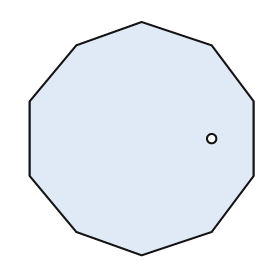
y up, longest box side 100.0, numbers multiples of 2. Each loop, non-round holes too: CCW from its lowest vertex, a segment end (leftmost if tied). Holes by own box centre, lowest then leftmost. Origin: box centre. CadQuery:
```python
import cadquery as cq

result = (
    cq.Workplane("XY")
    .moveTo(0.0, -50.0)
    .lineTo(30.0, -40.0)
    .lineTo(48.0, -16.0)
    .lineTo(48.0, 16.0)
    .lineTo(30.0, 40.0)
    .lineTo(0.0, 50.0)
    .lineTo(-28.0, 40.0)
    .lineTo(-48.0, 16.0)
    .lineTo(-48.0, -16.0)
    .lineTo(-28.0, -40.0)
    .close()
    .moveTo(30.0, 0.0)
    .circle(2.0)
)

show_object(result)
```